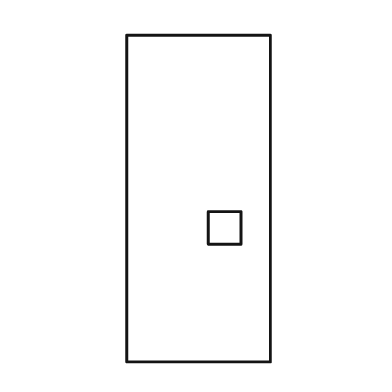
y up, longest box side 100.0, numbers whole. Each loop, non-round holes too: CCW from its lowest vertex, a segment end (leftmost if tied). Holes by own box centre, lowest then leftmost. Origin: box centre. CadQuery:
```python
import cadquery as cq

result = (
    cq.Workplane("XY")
    .moveTo(-22.0, -50.0)
    .lineTo(22.0, -50.0)
    .lineTo(22.0, 50.0)
    .lineTo(-22.0, 50.0)
    .close()
    .moveTo(3.0, -14.0)
    .lineTo(13.0, -14.0)
    .lineTo(13.0, -4.0)
    .lineTo(3.0, -4.0)
    .close()
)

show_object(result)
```